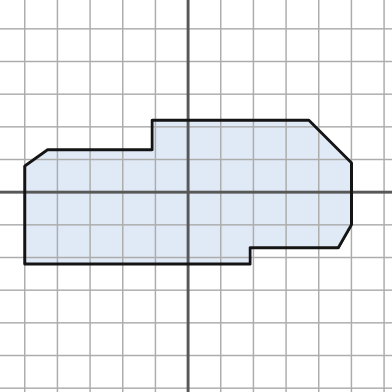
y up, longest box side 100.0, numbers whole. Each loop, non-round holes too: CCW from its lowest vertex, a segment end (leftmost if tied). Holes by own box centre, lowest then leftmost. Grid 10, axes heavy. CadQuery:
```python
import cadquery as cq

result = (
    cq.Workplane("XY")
    .moveTo(-50.0, -22.0)
    .lineTo(19.0, -22.0)
    .lineTo(19.0, -17.0)
    .lineTo(46.0, -17.0)
    .lineTo(50.0, -10.0)
    .lineTo(50.0, 9.0)
    .lineTo(37.0, 22.0)
    .lineTo(-11.0, 22.0)
    .lineTo(-11.0, 13.0)
    .lineTo(-43.0, 13.0)
    .lineTo(-50.0, 8.0)
    .close()
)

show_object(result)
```